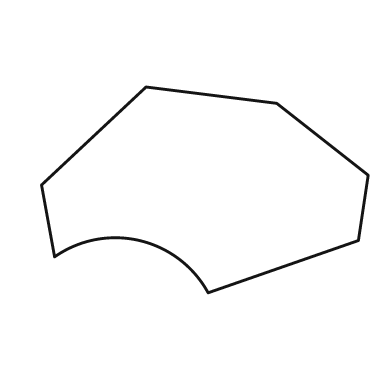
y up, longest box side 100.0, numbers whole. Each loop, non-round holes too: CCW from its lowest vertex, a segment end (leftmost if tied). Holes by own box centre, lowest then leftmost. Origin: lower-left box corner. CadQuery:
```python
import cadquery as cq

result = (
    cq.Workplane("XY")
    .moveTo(51.0, 0.0)
    .lineTo(97.0, 16.0)
    .lineTo(100.0, 36.0)
    .lineTo(72.0, 58.0)
    .lineTo(32.0, 63.0)
    .lineTo(0.0, 33.0)
    .lineTo(4.0, 11.0)
    .threePointArc((30.0, 16.0), (51.0, 0.0))
    .close()
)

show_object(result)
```